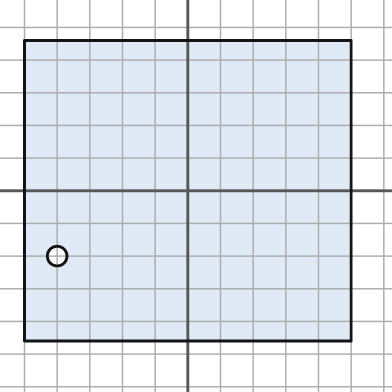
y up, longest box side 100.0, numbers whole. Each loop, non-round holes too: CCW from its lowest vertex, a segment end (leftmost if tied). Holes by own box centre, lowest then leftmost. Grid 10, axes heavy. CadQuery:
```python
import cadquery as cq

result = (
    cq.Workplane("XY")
    .moveTo(-50.0, -46.0)
    .lineTo(50.0, -46.0)
    .lineTo(50.0, 46.0)
    .lineTo(-50.0, 46.0)
    .close()
    .moveTo(-40.0, -20.0)
    .circle(3.0)
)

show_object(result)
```